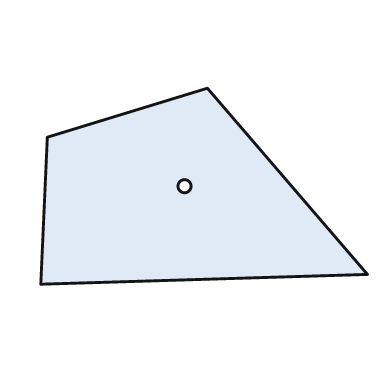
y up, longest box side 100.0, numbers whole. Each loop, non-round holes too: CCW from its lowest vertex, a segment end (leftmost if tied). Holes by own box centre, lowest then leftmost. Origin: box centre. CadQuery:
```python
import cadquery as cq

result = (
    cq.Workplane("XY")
    .moveTo(-50.0, -30.0)
    .lineTo(50.0, -27.0)
    .lineTo(1.0, 30.0)
    .lineTo(-48.0, 15.0)
    .close()
    .moveTo(-6.0, 0.0)
    .circle(2.0)
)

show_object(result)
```